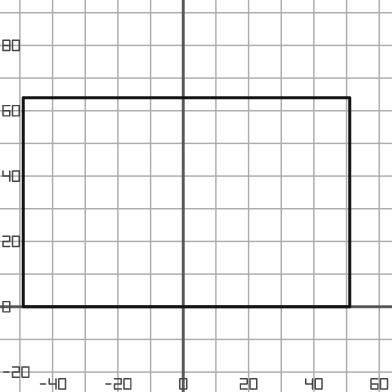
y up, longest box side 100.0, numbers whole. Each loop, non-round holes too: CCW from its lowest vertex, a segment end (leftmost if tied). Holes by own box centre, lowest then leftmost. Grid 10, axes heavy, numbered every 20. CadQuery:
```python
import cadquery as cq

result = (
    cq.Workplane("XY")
    .moveTo(-49.0, 0.0)
    .lineTo(51.0, 0.0)
    .lineTo(51.0, 64.0)
    .lineTo(-49.0, 64.0)
    .close()
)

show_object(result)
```